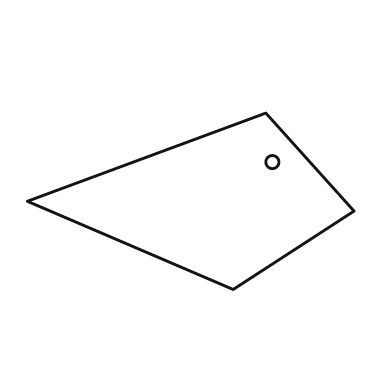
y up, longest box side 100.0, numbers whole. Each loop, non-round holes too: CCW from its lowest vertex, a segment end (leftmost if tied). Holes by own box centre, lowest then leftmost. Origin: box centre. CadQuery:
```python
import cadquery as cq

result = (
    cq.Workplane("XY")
    .moveTo(13.0, -27.0)
    .lineTo(50.0, -3.0)
    .lineTo(23.0, 27.0)
    .lineTo(-50.0, 0.0)
    .close()
    .moveTo(25.0, 12.0)
    .circle(2.0)
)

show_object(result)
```